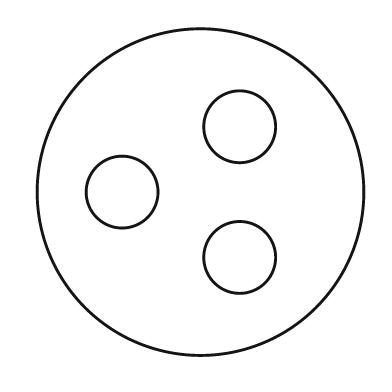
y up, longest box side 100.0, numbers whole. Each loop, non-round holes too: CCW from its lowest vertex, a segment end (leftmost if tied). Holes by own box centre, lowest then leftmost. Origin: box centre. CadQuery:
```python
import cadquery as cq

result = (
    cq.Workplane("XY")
    .moveTo(0.0, 0.0)
    .circle(50.0)
    .moveTo(12.0, -20.0)
    .circle(11.0)
    .moveTo(-24.0, 0.0)
    .circle(11.0)
    .moveTo(12.0, 20.0)
    .circle(11.0)
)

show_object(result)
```